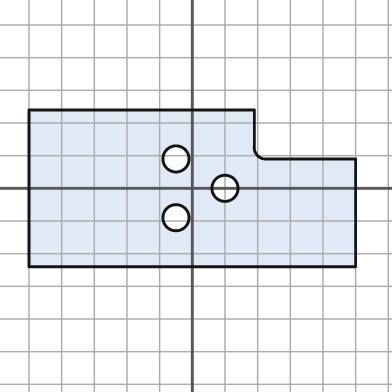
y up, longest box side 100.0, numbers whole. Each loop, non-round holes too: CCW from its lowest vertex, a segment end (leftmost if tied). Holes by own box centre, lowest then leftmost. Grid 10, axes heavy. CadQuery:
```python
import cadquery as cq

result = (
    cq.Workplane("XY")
    .moveTo(-50.0, -24.0)
    .lineTo(50.0, -24.0)
    .lineTo(50.0, 9.0)
    .lineTo(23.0, 9.0)
    .threePointArc((20.0, 10.0), (19.0, 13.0))
    .lineTo(19.0, 24.0)
    .lineTo(-50.0, 24.0)
    .close()
    .moveTo(-5.0, -9.0)
    .circle(4.0)
    .moveTo(10.0, 0.0)
    .circle(4.0)
    .moveTo(-5.0, 9.0)
    .circle(4.0)
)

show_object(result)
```